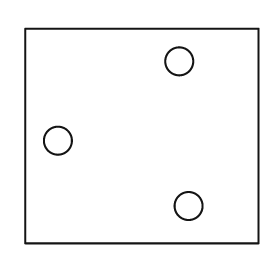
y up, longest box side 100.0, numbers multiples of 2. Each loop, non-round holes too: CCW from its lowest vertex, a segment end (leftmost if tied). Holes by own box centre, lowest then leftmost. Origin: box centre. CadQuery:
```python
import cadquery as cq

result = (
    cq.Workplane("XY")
    .moveTo(-50.0, -46.0)
    .lineTo(50.0, -46.0)
    .lineTo(50.0, 46.0)
    .lineTo(-50.0, 46.0)
    .close()
    .moveTo(20.0, -30.0)
    .circle(6.0)
    .moveTo(-36.0, -2.0)
    .circle(6.0)
    .moveTo(16.0, 32.0)
    .circle(6.0)
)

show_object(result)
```